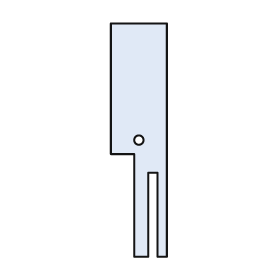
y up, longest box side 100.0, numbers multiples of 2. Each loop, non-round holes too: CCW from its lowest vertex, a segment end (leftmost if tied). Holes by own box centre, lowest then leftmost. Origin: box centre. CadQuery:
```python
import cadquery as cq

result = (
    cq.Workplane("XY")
    .moveTo(-2.0, -50.0)
    .lineTo(4.0, -50.0)
    .lineTo(4.0, -14.0)
    .lineTo(8.0, -14.0)
    .lineTo(8.0, -50.0)
    .lineTo(12.0, -50.0)
    .lineTo(12.0, 50.0)
    .lineTo(-12.0, 50.0)
    .lineTo(-12.0, -6.0)
    .lineTo(-2.0, -6.0)
    .close()
    .moveTo(0.0, 0.0)
    .circle(2.0)
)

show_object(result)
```